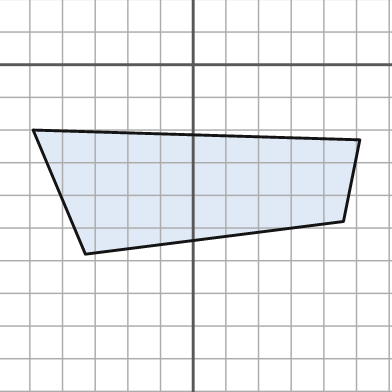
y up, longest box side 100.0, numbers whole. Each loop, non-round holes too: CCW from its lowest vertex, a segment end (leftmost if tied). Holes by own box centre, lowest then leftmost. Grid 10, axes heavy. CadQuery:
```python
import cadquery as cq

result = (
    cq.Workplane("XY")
    .moveTo(-33.0, -58.0)
    .lineTo(46.0, -48.0)
    .lineTo(51.0, -23.0)
    .lineTo(-49.0, -20.0)
    .close()
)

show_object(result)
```